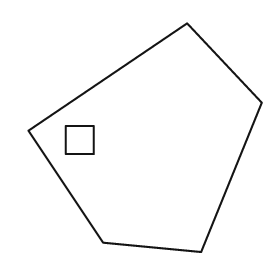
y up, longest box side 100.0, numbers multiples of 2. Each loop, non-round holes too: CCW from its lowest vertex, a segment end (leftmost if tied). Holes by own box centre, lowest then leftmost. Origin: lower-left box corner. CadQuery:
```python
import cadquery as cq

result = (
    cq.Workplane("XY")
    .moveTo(74.0, 0.0)
    .lineTo(100.0, 64.0)
    .lineTo(68.0, 98.0)
    .lineTo(0.0, 52.0)
    .lineTo(32.0, 4.0)
    .close()
    .moveTo(16.0, 42.0)
    .lineTo(28.0, 42.0)
    .lineTo(28.0, 54.0)
    .lineTo(16.0, 54.0)
    .close()
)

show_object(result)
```